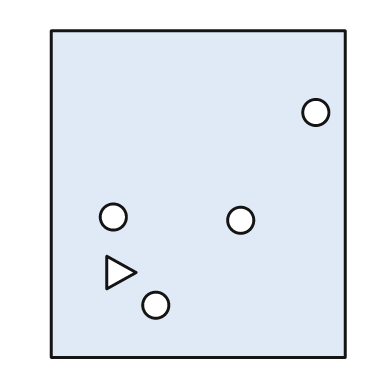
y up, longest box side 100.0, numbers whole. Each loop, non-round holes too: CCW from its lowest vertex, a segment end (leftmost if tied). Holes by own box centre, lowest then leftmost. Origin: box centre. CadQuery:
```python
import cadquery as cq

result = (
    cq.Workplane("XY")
    .moveTo(-45.0, -50.0)
    .lineTo(45.0, -50.0)
    .lineTo(45.0, 50.0)
    .lineTo(-45.0, 50.0)
    .close()
    .moveTo(-13.0, -34.0)
    .circle(4.0)
    .moveTo(-28.0, -29.0)
    .lineTo(-19.0, -24.0)
    .lineTo(-28.0, -19.0)
    .close()
    .moveTo(13.0, -8.0)
    .circle(4.0)
    .moveTo(-26.0, -7.0)
    .circle(4.0)
    .moveTo(36.0, 25.0)
    .circle(4.0)
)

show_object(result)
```